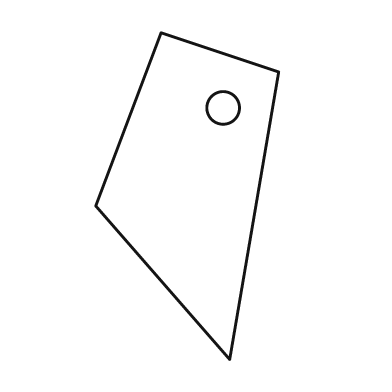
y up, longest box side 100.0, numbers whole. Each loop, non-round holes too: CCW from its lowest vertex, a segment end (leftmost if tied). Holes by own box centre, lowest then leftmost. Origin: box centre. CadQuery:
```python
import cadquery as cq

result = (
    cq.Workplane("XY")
    .moveTo(13.0, -50.0)
    .lineTo(28.0, 38.0)
    .lineTo(-8.0, 50.0)
    .lineTo(-28.0, -3.0)
    .close()
    .moveTo(11.0, 27.0)
    .circle(5.0)
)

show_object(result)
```